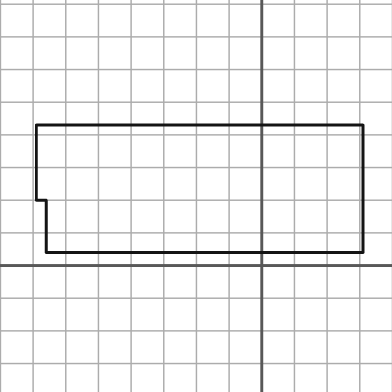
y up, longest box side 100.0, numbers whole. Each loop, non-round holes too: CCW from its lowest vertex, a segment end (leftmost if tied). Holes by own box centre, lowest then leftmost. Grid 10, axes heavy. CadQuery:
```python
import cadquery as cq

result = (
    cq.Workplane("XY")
    .moveTo(-66.0, 4.0)
    .lineTo(31.0, 4.0)
    .lineTo(31.0, 43.0)
    .lineTo(-69.0, 43.0)
    .lineTo(-69.0, 20.0)
    .lineTo(-66.0, 20.0)
    .close()
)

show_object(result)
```